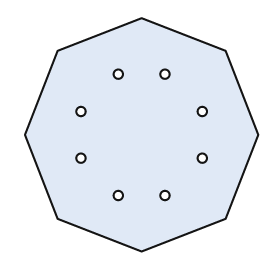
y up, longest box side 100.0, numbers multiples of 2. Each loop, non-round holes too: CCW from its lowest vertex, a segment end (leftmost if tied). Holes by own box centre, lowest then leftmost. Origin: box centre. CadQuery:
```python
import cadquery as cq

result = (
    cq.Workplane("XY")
    .moveTo(0.0, -50.0)
    .lineTo(36.0, -36.0)
    .lineTo(50.0, 0.0)
    .lineTo(36.0, 36.0)
    .lineTo(0.0, 50.0)
    .lineTo(-36.0, 36.0)
    .lineTo(-50.0, 0.0)
    .lineTo(-36.0, -36.0)
    .close()
    .moveTo(-10.0, -26.0)
    .circle(2.0)
    .moveTo(10.0, -26.0)
    .circle(2.0)
    .moveTo(-26.0, -10.0)
    .circle(2.0)
    .moveTo(26.0, -10.0)
    .circle(2.0)
    .moveTo(-26.0, 10.0)
    .circle(2.0)
    .moveTo(26.0, 10.0)
    .circle(2.0)
    .moveTo(-10.0, 26.0)
    .circle(2.0)
    .moveTo(10.0, 26.0)
    .circle(2.0)
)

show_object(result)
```